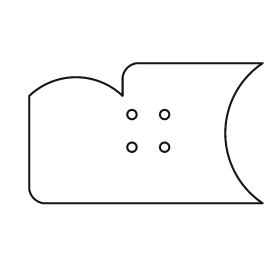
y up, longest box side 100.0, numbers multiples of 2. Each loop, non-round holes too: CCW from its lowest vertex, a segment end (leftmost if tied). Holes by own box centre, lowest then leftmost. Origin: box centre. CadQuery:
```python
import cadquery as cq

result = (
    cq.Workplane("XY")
    .moveTo(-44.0, -30.0)
    .lineTo(50.0, -30.0)
    .threePointArc((34.0, 0.0), (50.0, 30.0))
    .lineTo(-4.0, 30.0)
    .threePointArc((-8.0, 28.0), (-10.0, 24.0))
    .lineTo(-10.0, 16.0)
    .threePointArc((-30.0, 24.0), (-50.0, 16.0))
    .lineTo(-50.0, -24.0)
    .threePointArc((-48.0, -28.0), (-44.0, -30.0))
    .close()
    .moveTo(-6.0, -6.0)
    .circle(2.0)
    .moveTo(8.0, -6.0)
    .circle(2.0)
    .moveTo(-6.0, 8.0)
    .circle(2.0)
    .moveTo(8.0, 8.0)
    .circle(2.0)
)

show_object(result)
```